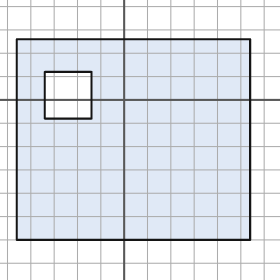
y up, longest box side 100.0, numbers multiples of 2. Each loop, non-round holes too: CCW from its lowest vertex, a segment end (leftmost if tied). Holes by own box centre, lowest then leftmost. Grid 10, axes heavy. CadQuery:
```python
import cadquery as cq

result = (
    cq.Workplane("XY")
    .moveTo(-46.0, -60.0)
    .lineTo(54.0, -60.0)
    .lineTo(54.0, 26.0)
    .lineTo(-46.0, 26.0)
    .close()
    .moveTo(-34.0, -8.0)
    .lineTo(-14.0, -8.0)
    .lineTo(-14.0, 12.0)
    .lineTo(-34.0, 12.0)
    .close()
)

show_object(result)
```